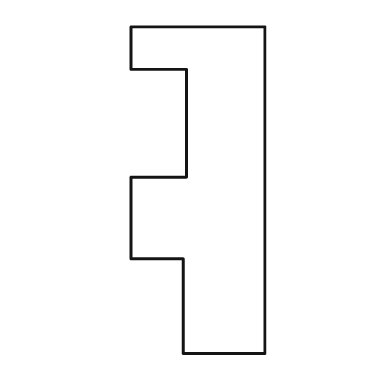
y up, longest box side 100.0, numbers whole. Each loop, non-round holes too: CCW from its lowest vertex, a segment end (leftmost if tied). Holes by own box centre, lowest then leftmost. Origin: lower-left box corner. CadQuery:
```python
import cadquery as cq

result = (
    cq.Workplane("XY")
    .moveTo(16.0, 0.0)
    .lineTo(41.0, 0.0)
    .lineTo(41.0, 100.0)
    .lineTo(0.0, 100.0)
    .lineTo(0.0, 87.0)
    .lineTo(17.0, 87.0)
    .lineTo(17.0, 54.0)
    .lineTo(0.0, 54.0)
    .lineTo(0.0, 29.0)
    .lineTo(16.0, 29.0)
    .close()
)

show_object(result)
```